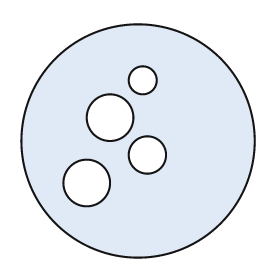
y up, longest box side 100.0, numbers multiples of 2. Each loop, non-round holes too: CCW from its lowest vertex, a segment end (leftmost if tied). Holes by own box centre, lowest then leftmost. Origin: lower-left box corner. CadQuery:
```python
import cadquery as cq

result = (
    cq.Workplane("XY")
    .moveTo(50.0, 50.0)
    .circle(50.0)
    .moveTo(28.0, 32.0)
    .circle(10.0)
    .moveTo(54.0, 44.0)
    .circle(8.0)
    .moveTo(38.0, 60.0)
    .circle(10.0)
    .moveTo(52.0, 76.0)
    .circle(6.0)
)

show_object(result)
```